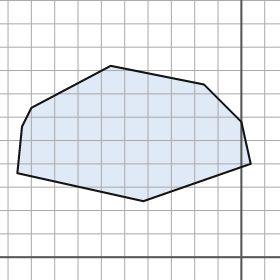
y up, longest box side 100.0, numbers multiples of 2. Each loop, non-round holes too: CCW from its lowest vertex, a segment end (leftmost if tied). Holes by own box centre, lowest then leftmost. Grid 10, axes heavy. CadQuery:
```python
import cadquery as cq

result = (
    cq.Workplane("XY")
    .moveTo(-42.0, 24.0)
    .lineTo(4.0, 40.0)
    .lineTo(0.0, 58.0)
    .lineTo(-16.0, 74.0)
    .lineTo(-56.0, 82.0)
    .lineTo(-90.0, 64.0)
    .lineTo(-94.0, 56.0)
    .lineTo(-96.0, 36.0)
    .close()
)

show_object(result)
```